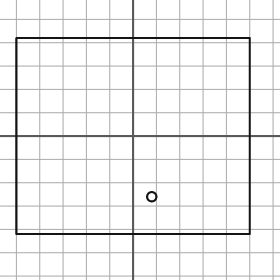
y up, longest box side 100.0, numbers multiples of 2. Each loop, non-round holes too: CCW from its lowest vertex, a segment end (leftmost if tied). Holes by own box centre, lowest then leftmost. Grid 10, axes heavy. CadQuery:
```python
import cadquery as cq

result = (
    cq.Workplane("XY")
    .moveTo(-50.0, -42.0)
    .lineTo(50.0, -42.0)
    .lineTo(50.0, 42.0)
    .lineTo(-50.0, 42.0)
    .close()
    .moveTo(8.0, -26.0)
    .circle(2.0)
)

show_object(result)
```